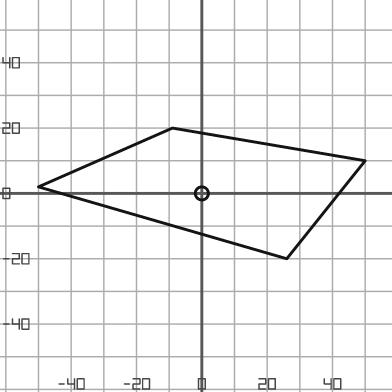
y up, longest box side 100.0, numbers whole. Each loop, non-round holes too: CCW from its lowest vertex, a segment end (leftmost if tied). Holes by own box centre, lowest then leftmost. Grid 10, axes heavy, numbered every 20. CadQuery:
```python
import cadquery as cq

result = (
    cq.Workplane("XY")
    .moveTo(26.0, -20.0)
    .lineTo(50.0, 10.0)
    .lineTo(-9.0, 20.0)
    .lineTo(-50.0, 2.0)
    .close()
    .moveTo(0.0, 0.0)
    .circle(2.0)
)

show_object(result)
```